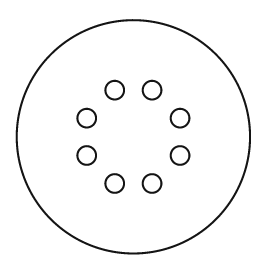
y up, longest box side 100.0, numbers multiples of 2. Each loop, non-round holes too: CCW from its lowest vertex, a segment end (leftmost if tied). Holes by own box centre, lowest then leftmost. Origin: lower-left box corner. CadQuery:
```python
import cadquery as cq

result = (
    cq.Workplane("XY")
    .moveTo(50.0, 50.0)
    .circle(50.0)
    .moveTo(42.0, 30.0)
    .circle(4.0)
    .moveTo(58.0, 30.0)
    .circle(4.0)
    .moveTo(30.0, 42.0)
    .circle(4.0)
    .moveTo(70.0, 42.0)
    .circle(4.0)
    .moveTo(30.0, 58.0)
    .circle(4.0)
    .moveTo(70.0, 58.0)
    .circle(4.0)
    .moveTo(42.0, 70.0)
    .circle(4.0)
    .moveTo(58.0, 70.0)
    .circle(4.0)
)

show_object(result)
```